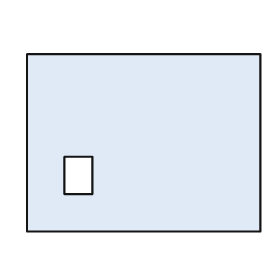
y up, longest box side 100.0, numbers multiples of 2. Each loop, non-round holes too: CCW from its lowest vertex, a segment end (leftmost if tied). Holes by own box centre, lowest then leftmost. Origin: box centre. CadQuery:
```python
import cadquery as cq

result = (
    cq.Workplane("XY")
    .moveTo(-50.0, -38.0)
    .lineTo(50.0, -38.0)
    .lineTo(50.0, 38.0)
    .lineTo(-50.0, 38.0)
    .close()
    .moveTo(-34.0, -22.0)
    .lineTo(-22.0, -22.0)
    .lineTo(-22.0, -6.0)
    .lineTo(-34.0, -6.0)
    .close()
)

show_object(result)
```